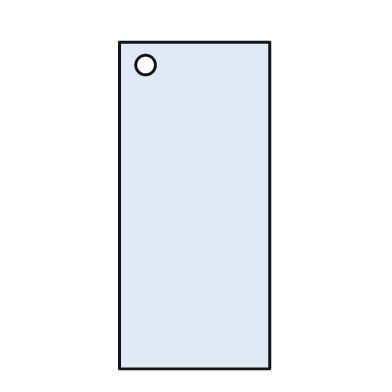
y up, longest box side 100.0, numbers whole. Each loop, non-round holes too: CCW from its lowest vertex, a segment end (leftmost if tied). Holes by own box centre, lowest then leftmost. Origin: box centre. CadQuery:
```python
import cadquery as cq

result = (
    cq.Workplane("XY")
    .moveTo(-23.0, -50.0)
    .lineTo(23.0, -50.0)
    .lineTo(23.0, 50.0)
    .lineTo(-23.0, 50.0)
    .close()
    .moveTo(-15.0, 43.0)
    .circle(3.0)
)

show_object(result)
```